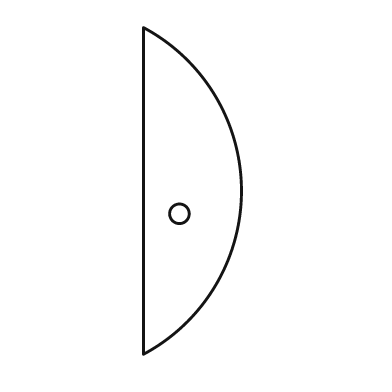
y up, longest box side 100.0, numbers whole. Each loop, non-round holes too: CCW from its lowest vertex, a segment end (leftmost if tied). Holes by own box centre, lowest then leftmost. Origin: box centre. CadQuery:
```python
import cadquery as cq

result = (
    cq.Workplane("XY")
    .moveTo(-15.0, -50.0)
    .threePointArc((15.0, 0.0), (-15.0, 50.0))
    .close()
    .moveTo(-4.0, -7.0)
    .circle(3.0)
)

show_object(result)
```